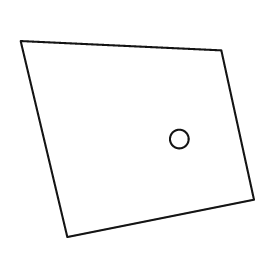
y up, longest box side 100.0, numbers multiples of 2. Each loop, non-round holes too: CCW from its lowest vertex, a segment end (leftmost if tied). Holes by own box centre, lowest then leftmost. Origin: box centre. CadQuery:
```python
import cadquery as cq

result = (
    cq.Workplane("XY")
    .moveTo(-30.0, -42.0)
    .lineTo(50.0, -26.0)
    .lineTo(36.0, 38.0)
    .lineTo(-50.0, 42.0)
    .close()
    .moveTo(18.0, 0.0)
    .circle(4.0)
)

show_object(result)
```